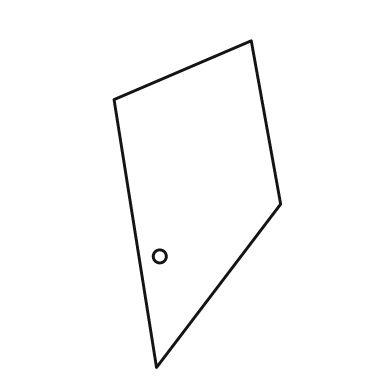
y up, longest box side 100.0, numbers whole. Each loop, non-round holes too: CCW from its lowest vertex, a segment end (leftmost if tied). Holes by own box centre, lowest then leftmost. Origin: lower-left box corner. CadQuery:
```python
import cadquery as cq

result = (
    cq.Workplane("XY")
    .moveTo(13.0, 0.0)
    .lineTo(51.0, 50.0)
    .lineTo(42.0, 100.0)
    .lineTo(0.0, 82.0)
    .close()
    .moveTo(14.0, 34.0)
    .circle(2.0)
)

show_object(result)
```